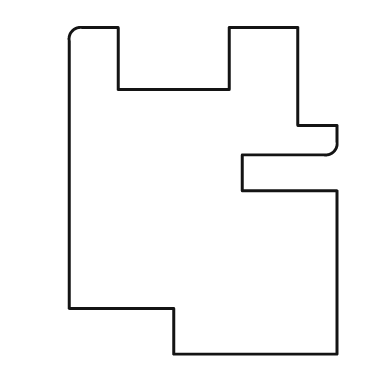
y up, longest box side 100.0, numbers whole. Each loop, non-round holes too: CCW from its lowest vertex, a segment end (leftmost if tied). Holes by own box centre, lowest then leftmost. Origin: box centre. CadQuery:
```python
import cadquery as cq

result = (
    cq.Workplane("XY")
    .moveTo(-9.0, -50.0)
    .lineTo(41.0, -50.0)
    .lineTo(41.0, 0.0)
    .lineTo(12.0, 0.0)
    .lineTo(12.0, 11.0)
    .lineTo(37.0, 11.0)
    .threePointArc((40.0, 12.0), (41.0, 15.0))
    .lineTo(41.0, 20.0)
    .lineTo(29.0, 20.0)
    .lineTo(29.0, 50.0)
    .lineTo(8.0, 50.0)
    .lineTo(8.0, 31.0)
    .lineTo(-26.0, 31.0)
    .lineTo(-26.0, 50.0)
    .lineTo(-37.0, 50.0)
    .threePointArc((-40.0, 49.0), (-41.0, 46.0))
    .lineTo(-41.0, -36.0)
    .lineTo(-9.0, -36.0)
    .close()
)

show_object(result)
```